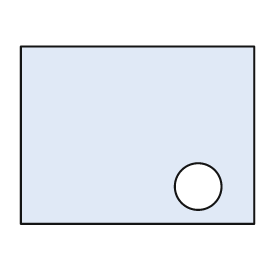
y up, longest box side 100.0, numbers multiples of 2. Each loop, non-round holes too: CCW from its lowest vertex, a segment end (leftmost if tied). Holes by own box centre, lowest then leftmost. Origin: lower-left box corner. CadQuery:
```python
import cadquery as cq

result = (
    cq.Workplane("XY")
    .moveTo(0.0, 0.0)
    .lineTo(100.0, 0.0)
    .lineTo(100.0, 76.0)
    .lineTo(0.0, 76.0)
    .close()
    .moveTo(76.0, 16.0)
    .circle(10.0)
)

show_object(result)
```